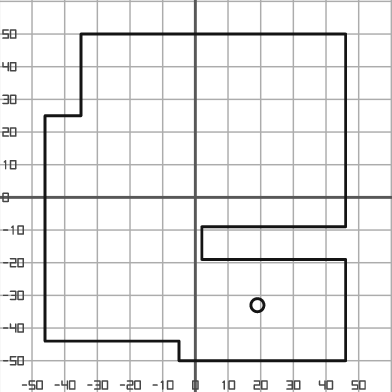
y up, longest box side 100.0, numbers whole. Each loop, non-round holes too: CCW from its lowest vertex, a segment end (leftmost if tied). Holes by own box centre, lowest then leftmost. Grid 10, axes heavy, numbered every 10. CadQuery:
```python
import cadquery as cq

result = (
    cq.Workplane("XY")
    .moveTo(-5.0, -50.0)
    .lineTo(46.0, -50.0)
    .lineTo(46.0, -19.0)
    .lineTo(2.0, -19.0)
    .lineTo(2.0, -9.0)
    .lineTo(46.0, -9.0)
    .lineTo(46.0, 50.0)
    .lineTo(-35.0, 50.0)
    .lineTo(-35.0, 25.0)
    .lineTo(-46.0, 25.0)
    .lineTo(-46.0, -44.0)
    .lineTo(-5.0, -44.0)
    .close()
    .moveTo(19.0, -33.0)
    .circle(2.0)
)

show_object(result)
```